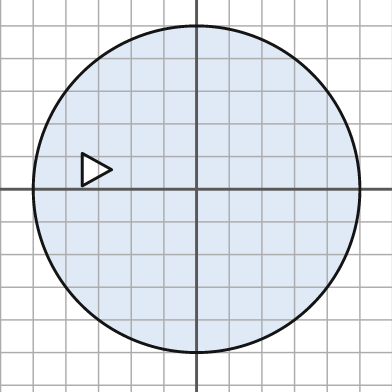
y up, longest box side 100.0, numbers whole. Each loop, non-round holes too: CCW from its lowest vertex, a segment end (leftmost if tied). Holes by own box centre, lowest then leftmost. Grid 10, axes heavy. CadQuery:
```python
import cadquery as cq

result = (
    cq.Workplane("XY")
    .moveTo(0.0, 0.0)
    .circle(50.0)
    .moveTo(-35.0, 1.0)
    .lineTo(-26.0, 6.0)
    .lineTo(-35.0, 11.0)
    .close()
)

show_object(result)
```